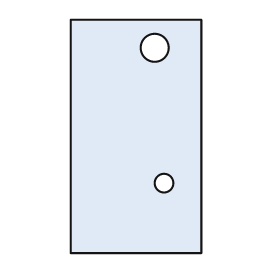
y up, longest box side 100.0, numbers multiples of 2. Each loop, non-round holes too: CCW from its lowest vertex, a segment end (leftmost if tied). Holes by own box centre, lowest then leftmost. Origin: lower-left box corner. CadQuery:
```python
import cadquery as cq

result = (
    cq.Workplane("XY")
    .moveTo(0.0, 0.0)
    .lineTo(56.0, 0.0)
    .lineTo(56.0, 100.0)
    .lineTo(0.0, 100.0)
    .close()
    .moveTo(40.0, 30.0)
    .circle(4.0)
    .moveTo(36.0, 88.0)
    .circle(6.0)
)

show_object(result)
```